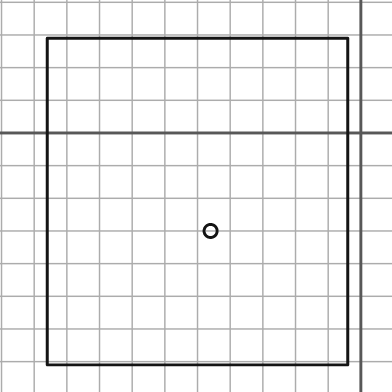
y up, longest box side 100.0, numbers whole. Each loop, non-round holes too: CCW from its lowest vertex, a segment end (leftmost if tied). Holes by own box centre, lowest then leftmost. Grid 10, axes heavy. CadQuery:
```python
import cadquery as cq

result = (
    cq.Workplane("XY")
    .moveTo(-96.0, -71.0)
    .lineTo(-4.0, -71.0)
    .lineTo(-4.0, 29.0)
    .lineTo(-96.0, 29.0)
    .close()
    .moveTo(-46.0, -30.0)
    .circle(2.0)
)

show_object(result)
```